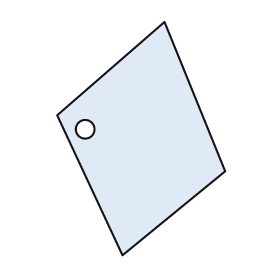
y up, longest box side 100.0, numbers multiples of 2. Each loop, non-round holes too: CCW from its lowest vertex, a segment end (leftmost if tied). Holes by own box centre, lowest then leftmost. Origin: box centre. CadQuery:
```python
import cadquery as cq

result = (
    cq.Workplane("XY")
    .moveTo(-8.0, -50.0)
    .lineTo(36.0, -14.0)
    .lineTo(10.0, 50.0)
    .lineTo(-36.0, 10.0)
    .close()
    .moveTo(-24.0, 4.0)
    .circle(4.0)
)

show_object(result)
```